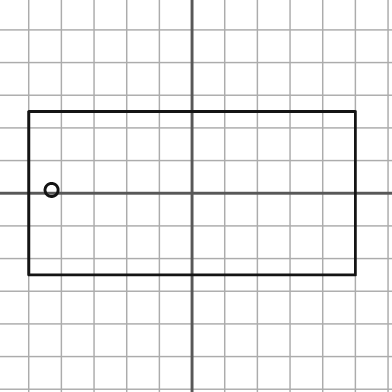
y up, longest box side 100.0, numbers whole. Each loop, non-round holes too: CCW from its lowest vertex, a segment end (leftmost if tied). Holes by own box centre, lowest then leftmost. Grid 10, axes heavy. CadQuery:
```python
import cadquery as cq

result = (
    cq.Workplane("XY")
    .moveTo(-50.0, -25.0)
    .lineTo(50.0, -25.0)
    .lineTo(50.0, 25.0)
    .lineTo(-50.0, 25.0)
    .close()
    .moveTo(-43.0, 1.0)
    .circle(2.0)
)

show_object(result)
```